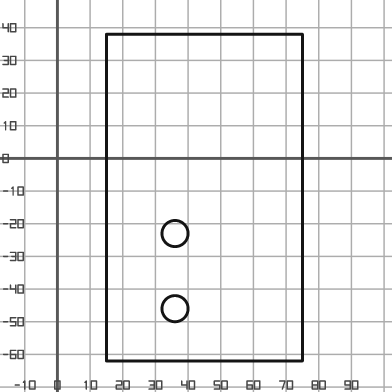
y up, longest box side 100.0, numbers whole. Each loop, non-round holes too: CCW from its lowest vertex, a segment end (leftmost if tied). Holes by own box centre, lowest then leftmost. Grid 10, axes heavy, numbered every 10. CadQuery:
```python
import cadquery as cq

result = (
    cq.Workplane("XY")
    .moveTo(15.0, -62.0)
    .lineTo(75.0, -62.0)
    .lineTo(75.0, 38.0)
    .lineTo(15.0, 38.0)
    .close()
    .moveTo(36.0, -46.0)
    .circle(4.0)
    .moveTo(36.0, -23.0)
    .circle(4.0)
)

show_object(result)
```